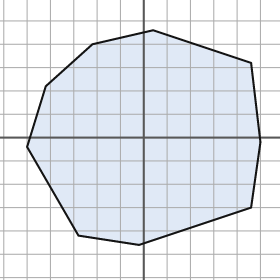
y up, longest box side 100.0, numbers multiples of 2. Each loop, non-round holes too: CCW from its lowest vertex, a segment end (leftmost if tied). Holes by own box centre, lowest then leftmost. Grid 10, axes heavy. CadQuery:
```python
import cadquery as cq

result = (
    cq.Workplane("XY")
    .moveTo(-2.0, -46.0)
    .lineTo(46.0, -30.0)
    .lineTo(50.0, -2.0)
    .lineTo(46.0, 32.0)
    .lineTo(4.0, 46.0)
    .lineTo(-22.0, 40.0)
    .lineTo(-42.0, 22.0)
    .lineTo(-50.0, -4.0)
    .lineTo(-28.0, -42.0)
    .close()
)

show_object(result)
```